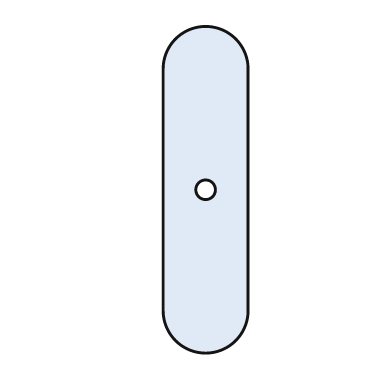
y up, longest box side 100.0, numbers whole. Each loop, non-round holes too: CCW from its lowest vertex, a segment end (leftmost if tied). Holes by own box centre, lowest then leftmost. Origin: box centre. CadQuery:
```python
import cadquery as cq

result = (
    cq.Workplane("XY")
    .moveTo(-13.0, -37.0)
    .threePointArc((0.0, -50.0), (13.0, -37.0))
    .lineTo(13.0, 37.0)
    .threePointArc((0.0, 50.0), (-13.0, 37.0))
    .close()
    .moveTo(0.0, 0.0)
    .circle(3.0)
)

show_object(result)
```